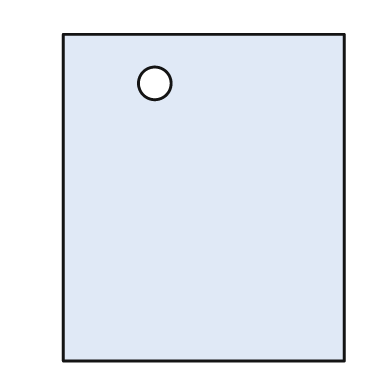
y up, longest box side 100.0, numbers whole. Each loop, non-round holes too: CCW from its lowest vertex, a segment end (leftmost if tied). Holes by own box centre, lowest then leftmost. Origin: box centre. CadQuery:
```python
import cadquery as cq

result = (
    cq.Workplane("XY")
    .moveTo(-43.0, -50.0)
    .lineTo(43.0, -50.0)
    .lineTo(43.0, 50.0)
    .lineTo(-43.0, 50.0)
    .close()
    .moveTo(-15.0, 35.0)
    .circle(5.0)
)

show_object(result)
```